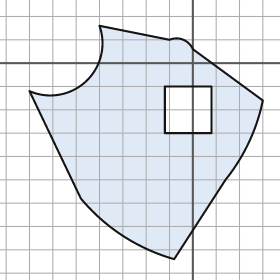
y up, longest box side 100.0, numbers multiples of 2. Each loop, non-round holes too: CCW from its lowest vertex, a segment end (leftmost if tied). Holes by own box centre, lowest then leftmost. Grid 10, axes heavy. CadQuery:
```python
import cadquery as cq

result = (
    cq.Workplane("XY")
    .moveTo(-8.0, -84.0)
    .lineTo(14.0, -50.0)
    .threePointArc((24.0, -34.0), (30.0, -16.0))
    .lineTo(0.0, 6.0)
    .threePointArc((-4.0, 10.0), (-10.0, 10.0))
    .lineTo(-40.0, 16.0)
    .threePointArc((-46.0, -8.0), (-70.0, -12.0))
    .lineTo(-48.0, -58.0)
    .threePointArc((-30.0, -74.0), (-8.0, -84.0))
    .close()
    .moveTo(-12.0, -30.0)
    .lineTo(8.0, -30.0)
    .lineTo(8.0, -10.0)
    .lineTo(-12.0, -10.0)
    .close()
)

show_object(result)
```